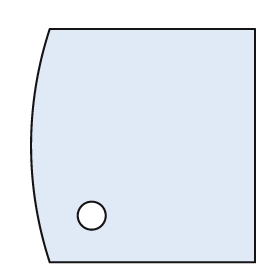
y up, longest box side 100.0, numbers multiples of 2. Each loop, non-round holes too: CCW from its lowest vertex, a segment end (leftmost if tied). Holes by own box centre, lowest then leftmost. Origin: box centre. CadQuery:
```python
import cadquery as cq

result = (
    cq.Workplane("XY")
    .moveTo(-40.0, -50.0)
    .lineTo(48.0, -50.0)
    .lineTo(48.0, 50.0)
    .lineTo(-40.0, 50.0)
    .threePointArc((-48.0, 0.0), (-40.0, -50.0))
    .close()
    .moveTo(-22.0, -30.0)
    .circle(6.0)
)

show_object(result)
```